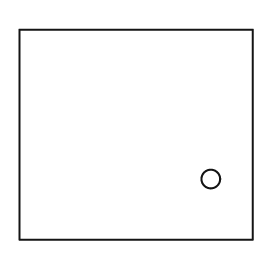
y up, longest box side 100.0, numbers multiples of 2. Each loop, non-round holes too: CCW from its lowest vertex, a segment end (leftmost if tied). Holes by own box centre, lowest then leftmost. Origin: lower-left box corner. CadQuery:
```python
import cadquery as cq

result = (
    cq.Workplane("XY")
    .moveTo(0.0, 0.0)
    .lineTo(100.0, 0.0)
    .lineTo(100.0, 90.0)
    .lineTo(0.0, 90.0)
    .close()
    .moveTo(82.0, 26.0)
    .circle(4.0)
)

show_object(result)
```